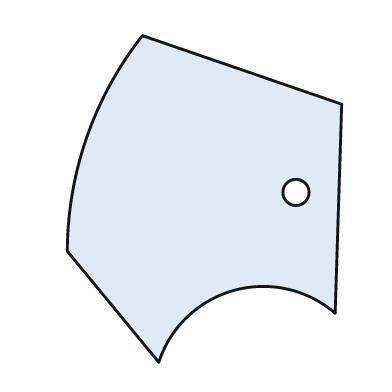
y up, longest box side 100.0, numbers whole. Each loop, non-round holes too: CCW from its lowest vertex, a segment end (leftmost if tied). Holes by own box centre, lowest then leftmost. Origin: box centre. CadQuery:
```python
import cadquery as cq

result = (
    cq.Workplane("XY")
    .moveTo(-14.0, -50.0)
    .threePointArc((9.0, -28.0), (40.0, -35.0))
    .lineTo(42.0, 29.0)
    .lineTo(-19.0, 50.0)
    .threePointArc((-36.0, 19.0), (-42.0, -16.0))
    .close()
    .moveTo(28.0, 2.0)
    .circle(4.0)
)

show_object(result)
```